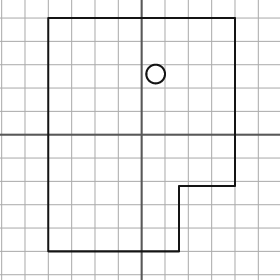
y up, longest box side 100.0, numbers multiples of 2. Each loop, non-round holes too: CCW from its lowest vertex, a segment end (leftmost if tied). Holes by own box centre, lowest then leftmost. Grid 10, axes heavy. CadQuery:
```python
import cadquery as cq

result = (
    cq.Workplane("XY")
    .moveTo(-40.0, -50.0)
    .lineTo(16.0, -50.0)
    .lineTo(16.0, -22.0)
    .lineTo(40.0, -22.0)
    .lineTo(40.0, 50.0)
    .lineTo(-40.0, 50.0)
    .close()
    .moveTo(6.0, 26.0)
    .circle(4.0)
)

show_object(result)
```